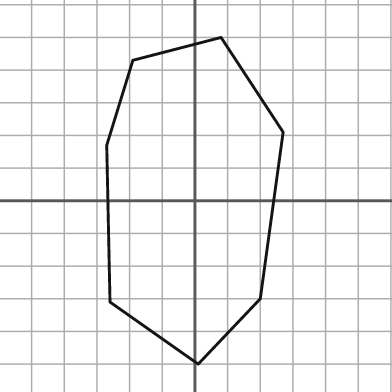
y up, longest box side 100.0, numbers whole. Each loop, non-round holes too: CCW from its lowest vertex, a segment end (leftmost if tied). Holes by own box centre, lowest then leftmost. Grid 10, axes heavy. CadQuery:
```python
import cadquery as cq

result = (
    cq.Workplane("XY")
    .moveTo(1.0, -50.0)
    .lineTo(20.0, -30.0)
    .lineTo(27.0, 21.0)
    .lineTo(8.0, 50.0)
    .lineTo(-19.0, 43.0)
    .lineTo(-27.0, 17.0)
    .lineTo(-26.0, -31.0)
    .close()
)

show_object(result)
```